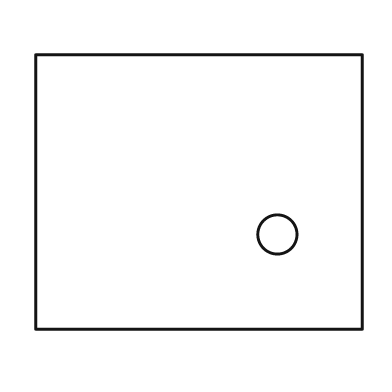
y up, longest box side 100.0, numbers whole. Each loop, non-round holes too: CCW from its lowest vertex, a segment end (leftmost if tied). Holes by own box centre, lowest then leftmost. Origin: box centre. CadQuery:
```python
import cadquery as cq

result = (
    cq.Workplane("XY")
    .moveTo(-50.0, -42.0)
    .lineTo(50.0, -42.0)
    .lineTo(50.0, 42.0)
    .lineTo(-50.0, 42.0)
    .close()
    .moveTo(24.0, -13.0)
    .circle(6.0)
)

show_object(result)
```